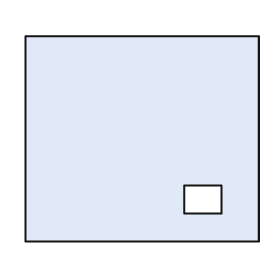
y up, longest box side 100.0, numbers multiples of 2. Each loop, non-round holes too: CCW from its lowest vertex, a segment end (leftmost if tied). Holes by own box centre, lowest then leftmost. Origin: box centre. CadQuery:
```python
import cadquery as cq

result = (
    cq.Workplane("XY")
    .moveTo(-50.0, -44.0)
    .lineTo(50.0, -44.0)
    .lineTo(50.0, 44.0)
    .lineTo(-50.0, 44.0)
    .close()
    .moveTo(18.0, -32.0)
    .lineTo(34.0, -32.0)
    .lineTo(34.0, -20.0)
    .lineTo(18.0, -20.0)
    .close()
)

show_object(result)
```